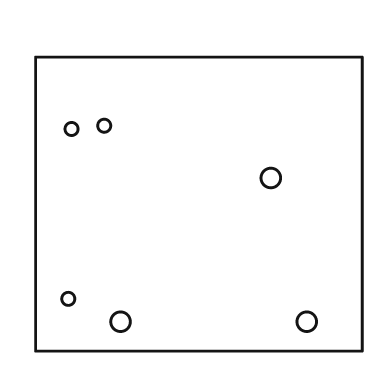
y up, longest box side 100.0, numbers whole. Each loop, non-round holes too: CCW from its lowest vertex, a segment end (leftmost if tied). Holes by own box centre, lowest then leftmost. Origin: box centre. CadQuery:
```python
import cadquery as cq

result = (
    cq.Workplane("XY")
    .moveTo(-50.0, -45.0)
    .lineTo(50.0, -45.0)
    .lineTo(50.0, 45.0)
    .lineTo(-50.0, 45.0)
    .close()
    .moveTo(-24.0, -36.0)
    .circle(3.0)
    .moveTo(33.0, -36.0)
    .circle(3.0)
    .moveTo(-40.0, -29.0)
    .circle(2.0)
    .moveTo(22.0, 8.0)
    .circle(3.0)
    .moveTo(-39.0, 23.0)
    .circle(2.0)
    .moveTo(-29.0, 24.0)
    .circle(2.0)
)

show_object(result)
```